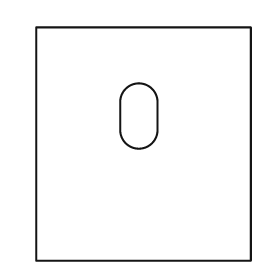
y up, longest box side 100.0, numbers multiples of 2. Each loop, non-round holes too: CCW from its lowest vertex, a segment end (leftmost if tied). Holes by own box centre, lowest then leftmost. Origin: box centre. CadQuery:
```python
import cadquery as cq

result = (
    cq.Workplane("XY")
    .moveTo(-46.0, -50.0)
    .lineTo(46.0, -50.0)
    .lineTo(46.0, 50.0)
    .lineTo(-46.0, 50.0)
    .close()
    .moveTo(-10.0, 6.0)
    .threePointArc((-2.0, -2.0), (6.0, 6.0))
    .lineTo(6.0, 18.0)
    .threePointArc((-2.0, 26.0), (-10.0, 18.0))
    .close()
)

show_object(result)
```